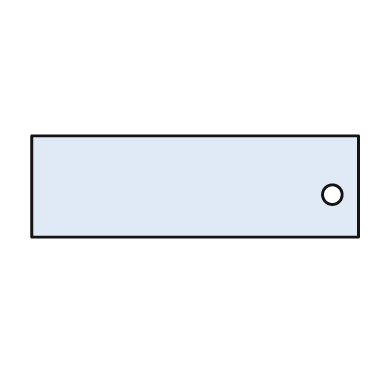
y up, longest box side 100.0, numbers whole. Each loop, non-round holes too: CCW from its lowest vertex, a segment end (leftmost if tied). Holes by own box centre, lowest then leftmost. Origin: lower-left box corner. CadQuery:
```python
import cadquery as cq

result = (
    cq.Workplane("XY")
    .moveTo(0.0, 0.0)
    .lineTo(100.0, 0.0)
    .lineTo(100.0, 31.0)
    .lineTo(0.0, 31.0)
    .close()
    .moveTo(92.0, 13.0)
    .circle(3.0)
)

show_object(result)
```